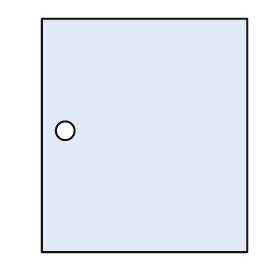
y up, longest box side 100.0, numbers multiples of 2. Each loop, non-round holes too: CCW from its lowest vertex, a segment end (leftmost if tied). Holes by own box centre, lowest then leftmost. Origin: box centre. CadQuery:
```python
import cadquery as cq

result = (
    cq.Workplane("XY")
    .moveTo(-44.0, -50.0)
    .lineTo(44.0, -50.0)
    .lineTo(44.0, 50.0)
    .lineTo(-44.0, 50.0)
    .close()
    .moveTo(-34.0, 2.0)
    .circle(4.0)
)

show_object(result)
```